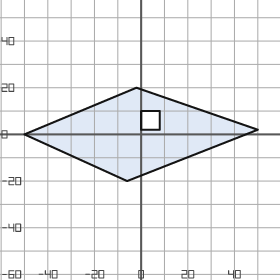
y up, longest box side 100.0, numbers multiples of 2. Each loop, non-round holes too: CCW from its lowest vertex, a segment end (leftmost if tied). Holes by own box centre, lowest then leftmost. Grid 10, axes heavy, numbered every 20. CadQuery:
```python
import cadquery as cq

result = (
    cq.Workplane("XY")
    .moveTo(-6.0, -20.0)
    .lineTo(50.0, 2.0)
    .lineTo(-2.0, 20.0)
    .lineTo(-50.0, 0.0)
    .close()
    .moveTo(0.0, 2.0)
    .lineTo(8.0, 2.0)
    .lineTo(8.0, 10.0)
    .lineTo(0.0, 10.0)
    .close()
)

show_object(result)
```